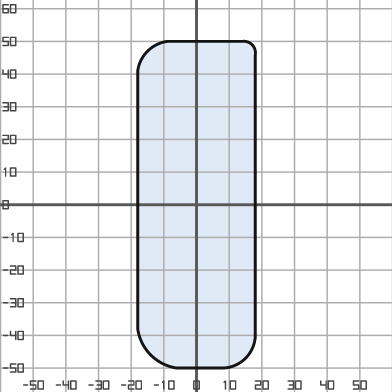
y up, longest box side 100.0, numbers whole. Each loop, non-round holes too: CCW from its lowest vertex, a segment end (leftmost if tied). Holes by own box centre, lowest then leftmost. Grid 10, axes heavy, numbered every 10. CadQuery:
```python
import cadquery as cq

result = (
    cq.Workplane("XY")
    .moveTo(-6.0, -50.0)
    .lineTo(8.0, -50.0)
    .threePointArc((15.0, -47.0), (18.0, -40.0))
    .lineTo(18.0, 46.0)
    .threePointArc((17.0, 49.0), (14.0, 50.0))
    .lineTo(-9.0, 50.0)
    .threePointArc((-15.0, 47.0), (-18.0, 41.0))
    .lineTo(-18.0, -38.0)
    .threePointArc((-14.0, -46.0), (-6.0, -50.0))
    .close()
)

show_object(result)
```